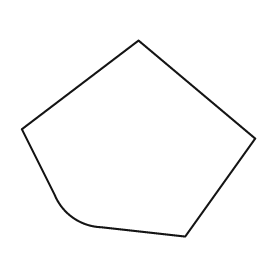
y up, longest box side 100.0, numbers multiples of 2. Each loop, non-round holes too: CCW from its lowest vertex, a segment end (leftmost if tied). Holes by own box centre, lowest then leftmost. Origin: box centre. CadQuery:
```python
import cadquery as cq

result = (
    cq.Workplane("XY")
    .moveTo(20.0, -42.0)
    .lineTo(50.0, 0.0)
    .lineTo(0.0, 42.0)
    .lineTo(-50.0, 4.0)
    .lineTo(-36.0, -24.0)
    .threePointArc((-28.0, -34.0), (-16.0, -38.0))
    .close()
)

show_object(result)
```